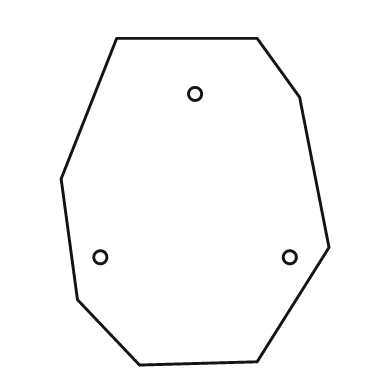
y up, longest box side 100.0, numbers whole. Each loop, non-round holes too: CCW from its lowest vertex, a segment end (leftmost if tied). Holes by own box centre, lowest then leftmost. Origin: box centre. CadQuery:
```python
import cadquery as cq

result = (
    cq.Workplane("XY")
    .moveTo(-17.0, -50.0)
    .lineTo(19.0, -49.0)
    .lineTo(41.0, -14.0)
    .lineTo(32.0, 32.0)
    .lineTo(19.0, 50.0)
    .lineTo(-24.0, 50.0)
    .lineTo(-41.0, 7.0)
    .lineTo(-36.0, -30.0)
    .close()
    .moveTo(-29.0, -17.0)
    .circle(2.0)
    .moveTo(29.0, -17.0)
    .circle(2.0)
    .moveTo(0.0, 33.0)
    .circle(2.0)
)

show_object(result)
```